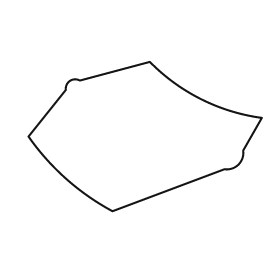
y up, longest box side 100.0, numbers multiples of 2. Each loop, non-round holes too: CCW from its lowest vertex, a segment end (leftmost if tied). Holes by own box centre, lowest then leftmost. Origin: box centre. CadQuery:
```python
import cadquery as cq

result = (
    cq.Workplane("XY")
    .moveTo(-14.0, -32.0)
    .lineTo(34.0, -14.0)
    .threePointArc((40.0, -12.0), (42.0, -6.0))
    .lineTo(50.0, 8.0)
    .threePointArc((24.0, 16.0), (2.0, 32.0))
    .lineTo(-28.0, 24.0)
    .threePointArc((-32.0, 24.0), (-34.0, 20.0))
    .lineTo(-50.0, 0.0)
    .threePointArc((-34.0, -18.0), (-14.0, -32.0))
    .close()
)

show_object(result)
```